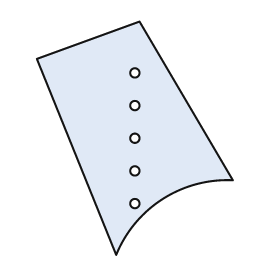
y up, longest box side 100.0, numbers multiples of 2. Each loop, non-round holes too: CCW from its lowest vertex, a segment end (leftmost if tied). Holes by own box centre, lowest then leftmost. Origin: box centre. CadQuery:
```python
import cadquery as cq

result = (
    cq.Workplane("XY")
    .moveTo(-8.0, -50.0)
    .threePointArc((12.0, -26.0), (42.0, -18.0))
    .lineTo(2.0, 50.0)
    .lineTo(-42.0, 34.0)
    .close()
    .moveTo(0.0, -28.0)
    .circle(2.0)
    .moveTo(0.0, -14.0)
    .circle(2.0)
    .moveTo(0.0, 0.0)
    .circle(2.0)
    .moveTo(0.0, 14.0)
    .circle(2.0)
    .moveTo(0.0, 28.0)
    .circle(2.0)
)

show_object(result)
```